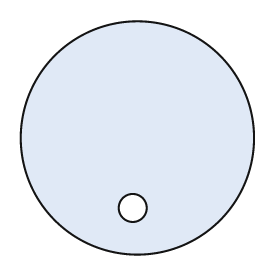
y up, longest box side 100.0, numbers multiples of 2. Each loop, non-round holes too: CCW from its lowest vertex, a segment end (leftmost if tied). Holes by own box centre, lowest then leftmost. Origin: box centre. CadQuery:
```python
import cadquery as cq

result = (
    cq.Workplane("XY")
    .moveTo(0.0, 0.0)
    .circle(50.0)
    .moveTo(-2.0, -30.0)
    .circle(6.0)
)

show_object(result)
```